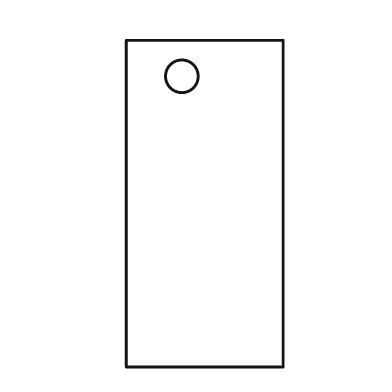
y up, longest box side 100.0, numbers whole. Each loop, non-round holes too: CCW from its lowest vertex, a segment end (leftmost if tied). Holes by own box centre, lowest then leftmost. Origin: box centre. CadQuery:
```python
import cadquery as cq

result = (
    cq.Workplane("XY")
    .moveTo(-24.0, -50.0)
    .lineTo(24.0, -50.0)
    .lineTo(24.0, 50.0)
    .lineTo(-24.0, 50.0)
    .close()
    .moveTo(-7.0, 39.0)
    .circle(5.0)
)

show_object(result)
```